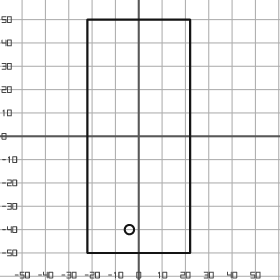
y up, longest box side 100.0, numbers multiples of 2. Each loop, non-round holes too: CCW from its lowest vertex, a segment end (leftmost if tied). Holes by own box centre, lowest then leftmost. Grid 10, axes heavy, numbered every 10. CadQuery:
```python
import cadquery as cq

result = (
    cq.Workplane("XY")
    .moveTo(-22.0, -50.0)
    .lineTo(22.0, -50.0)
    .lineTo(22.0, 50.0)
    .lineTo(-22.0, 50.0)
    .close()
    .moveTo(-4.0, -40.0)
    .circle(2.0)
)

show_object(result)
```